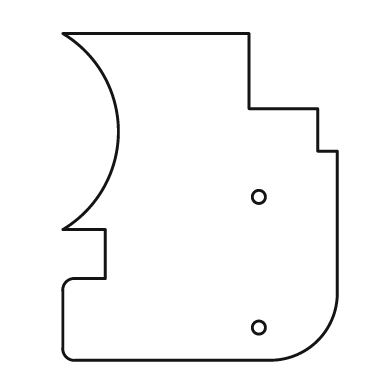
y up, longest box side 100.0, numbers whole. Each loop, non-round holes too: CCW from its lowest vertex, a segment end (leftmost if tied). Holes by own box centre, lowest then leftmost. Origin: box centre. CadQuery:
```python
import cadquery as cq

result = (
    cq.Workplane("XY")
    .moveTo(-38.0, -50.0)
    .lineTo(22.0, -50.0)
    .threePointArc((36.0, -44.0), (42.0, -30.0))
    .lineTo(42.0, 14.0)
    .lineTo(36.0, 14.0)
    .lineTo(36.0, 27.0)
    .lineTo(15.0, 27.0)
    .lineTo(15.0, 50.0)
    .lineTo(-42.0, 50.0)
    .threePointArc((-25.0, 20.0), (-42.0, -10.0))
    .lineTo(-29.0, -10.0)
    .lineTo(-29.0, -25.0)
    .lineTo(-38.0, -25.0)
    .threePointArc((-41.0, -26.0), (-42.0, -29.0))
    .lineTo(-42.0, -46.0)
    .threePointArc((-41.0, -49.0), (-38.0, -50.0))
    .close()
    .moveTo(18.0, -40.0)
    .circle(2.0)
    .moveTo(18.0, 0.0)
    .circle(2.0)
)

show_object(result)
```